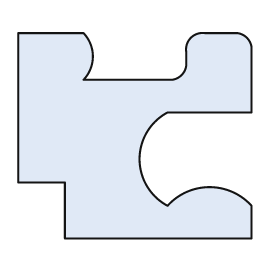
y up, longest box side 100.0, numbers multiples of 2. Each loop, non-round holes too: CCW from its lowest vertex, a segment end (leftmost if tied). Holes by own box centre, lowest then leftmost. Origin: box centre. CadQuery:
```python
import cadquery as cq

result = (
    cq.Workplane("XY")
    .moveTo(-30.0, -44.0)
    .lineTo(50.0, -44.0)
    .lineTo(50.0, -30.0)
    .threePointArc((32.0, -22.0), (14.0, -30.0))
    .threePointArc((2.0, -10.0), (14.0, 10.0))
    .lineTo(50.0, 10.0)
    .lineTo(50.0, 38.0)
    .threePointArc((48.0, 42.0), (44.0, 44.0))
    .lineTo(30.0, 44.0)
    .threePointArc((24.0, 42.0), (22.0, 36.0))
    .lineTo(22.0, 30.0)
    .threePointArc((20.0, 26.0), (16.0, 24.0))
    .lineTo(-22.0, 24.0)
    .threePointArc((-18.0, 34.0), (-22.0, 44.0))
    .lineTo(-50.0, 44.0)
    .lineTo(-50.0, -20.0)
    .lineTo(-30.0, -20.0)
    .close()
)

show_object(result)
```